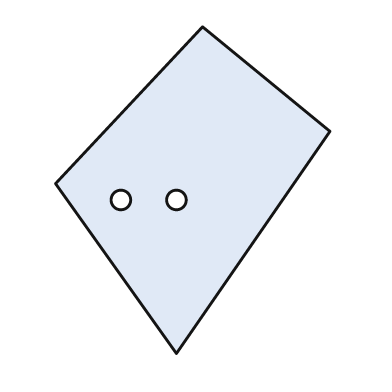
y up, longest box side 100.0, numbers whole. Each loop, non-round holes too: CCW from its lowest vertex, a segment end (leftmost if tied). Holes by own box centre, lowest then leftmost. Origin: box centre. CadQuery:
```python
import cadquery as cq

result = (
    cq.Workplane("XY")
    .moveTo(-5.0, -50.0)
    .lineTo(42.0, 18.0)
    .lineTo(3.0, 50.0)
    .lineTo(-42.0, 2.0)
    .close()
    .moveTo(-22.0, -3.0)
    .circle(3.0)
    .moveTo(-5.0, -3.0)
    .circle(3.0)
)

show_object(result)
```